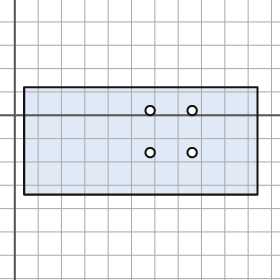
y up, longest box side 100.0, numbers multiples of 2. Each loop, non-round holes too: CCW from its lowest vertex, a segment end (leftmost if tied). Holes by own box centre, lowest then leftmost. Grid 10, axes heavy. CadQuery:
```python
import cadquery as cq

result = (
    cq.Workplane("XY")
    .moveTo(4.0, -34.0)
    .lineTo(104.0, -34.0)
    .lineTo(104.0, 12.0)
    .lineTo(4.0, 12.0)
    .close()
    .moveTo(58.0, -16.0)
    .circle(2.0)
    .moveTo(76.0, -16.0)
    .circle(2.0)
    .moveTo(58.0, 2.0)
    .circle(2.0)
    .moveTo(76.0, 2.0)
    .circle(2.0)
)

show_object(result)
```